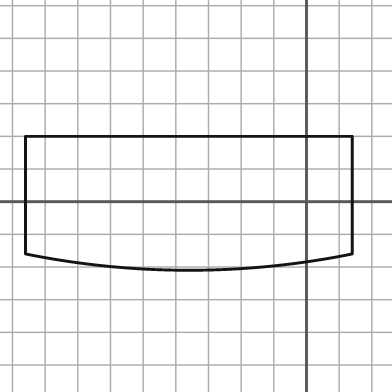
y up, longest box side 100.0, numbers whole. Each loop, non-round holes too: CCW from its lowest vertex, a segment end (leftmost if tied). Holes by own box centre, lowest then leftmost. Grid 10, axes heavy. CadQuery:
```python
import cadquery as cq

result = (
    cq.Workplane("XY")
    .moveTo(-86.0, -16.0)
    .threePointArc((-36.0, -21.0), (14.0, -16.0))
    .lineTo(14.0, 20.0)
    .lineTo(-86.0, 20.0)
    .close()
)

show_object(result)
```